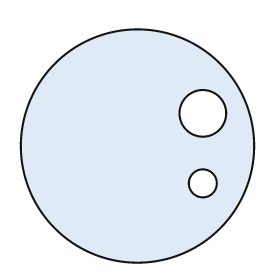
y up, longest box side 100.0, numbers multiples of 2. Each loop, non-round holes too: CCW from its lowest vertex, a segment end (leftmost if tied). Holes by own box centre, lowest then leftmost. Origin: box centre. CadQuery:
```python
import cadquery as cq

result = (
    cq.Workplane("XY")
    .moveTo(0.0, 0.0)
    .circle(50.0)
    .moveTo(28.0, -16.0)
    .circle(6.0)
    .moveTo(28.0, 14.0)
    .circle(10.0)
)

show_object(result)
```